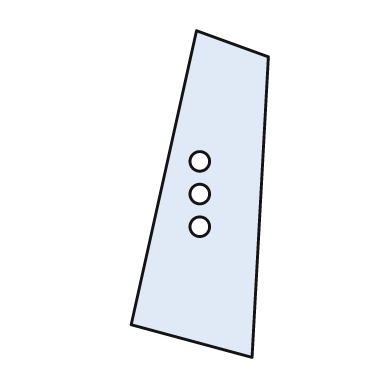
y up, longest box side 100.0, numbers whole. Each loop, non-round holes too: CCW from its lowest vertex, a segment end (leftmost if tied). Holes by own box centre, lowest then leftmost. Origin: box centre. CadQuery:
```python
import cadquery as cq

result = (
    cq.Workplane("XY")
    .moveTo(16.0, -50.0)
    .lineTo(21.0, 42.0)
    .lineTo(-1.0, 50.0)
    .lineTo(-21.0, -40.0)
    .close()
    .moveTo(0.0, -10.0)
    .circle(3.0)
    .moveTo(0.0, 0.0)
    .circle(3.0)
    .moveTo(0.0, 10.0)
    .circle(3.0)
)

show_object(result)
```